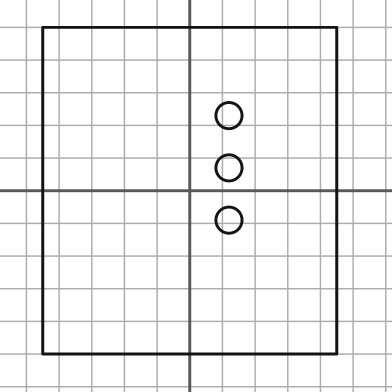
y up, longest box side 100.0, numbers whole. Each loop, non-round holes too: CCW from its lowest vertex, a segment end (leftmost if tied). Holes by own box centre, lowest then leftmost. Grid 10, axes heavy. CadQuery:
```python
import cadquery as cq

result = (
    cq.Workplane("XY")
    .moveTo(-45.0, -50.0)
    .lineTo(45.0, -50.0)
    .lineTo(45.0, 50.0)
    .lineTo(-45.0, 50.0)
    .close()
    .moveTo(12.0, -9.0)
    .circle(4.0)
    .moveTo(12.0, 7.0)
    .circle(4.0)
    .moveTo(12.0, 23.0)
    .circle(4.0)
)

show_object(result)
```